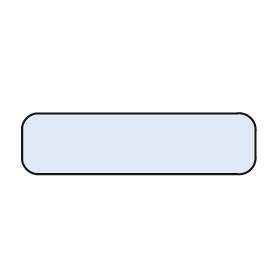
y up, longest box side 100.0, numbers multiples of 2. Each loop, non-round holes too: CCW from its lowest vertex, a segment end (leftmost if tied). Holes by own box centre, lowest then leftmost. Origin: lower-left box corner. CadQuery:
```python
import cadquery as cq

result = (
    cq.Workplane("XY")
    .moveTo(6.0, 0.0)
    .lineTo(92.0, 0.0)
    .threePointArc((98.0, 2.0), (100.0, 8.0))
    .lineTo(100.0, 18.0)
    .threePointArc((98.0, 24.0), (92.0, 26.0))
    .lineTo(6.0, 26.0)
    .threePointArc((2.0, 24.0), (0.0, 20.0))
    .lineTo(0.0, 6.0)
    .threePointArc((2.0, 2.0), (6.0, 0.0))
    .close()
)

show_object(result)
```